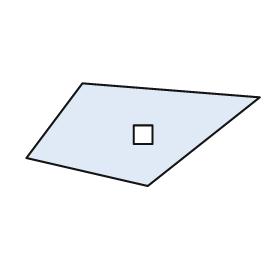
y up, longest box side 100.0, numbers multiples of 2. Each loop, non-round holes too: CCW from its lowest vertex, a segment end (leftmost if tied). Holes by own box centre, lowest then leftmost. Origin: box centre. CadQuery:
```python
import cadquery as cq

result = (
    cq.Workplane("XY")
    .moveTo(2.0, -22.0)
    .lineTo(50.0, 16.0)
    .lineTo(-26.0, 22.0)
    .lineTo(-50.0, -10.0)
    .close()
    .moveTo(-4.0, -4.0)
    .lineTo(4.0, -4.0)
    .lineTo(4.0, 4.0)
    .lineTo(-4.0, 4.0)
    .close()
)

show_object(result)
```